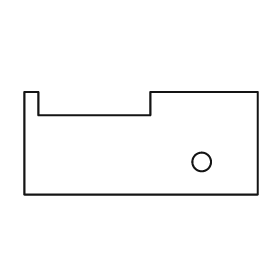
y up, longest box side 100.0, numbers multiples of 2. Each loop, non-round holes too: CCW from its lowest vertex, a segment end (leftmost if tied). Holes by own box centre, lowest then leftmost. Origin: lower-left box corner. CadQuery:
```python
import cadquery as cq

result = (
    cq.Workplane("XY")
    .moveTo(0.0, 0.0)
    .lineTo(100.0, 0.0)
    .lineTo(100.0, 44.0)
    .lineTo(54.0, 44.0)
    .lineTo(54.0, 34.0)
    .lineTo(6.0, 34.0)
    .lineTo(6.0, 44.0)
    .lineTo(0.0, 44.0)
    .close()
    .moveTo(76.0, 14.0)
    .circle(4.0)
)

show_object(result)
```